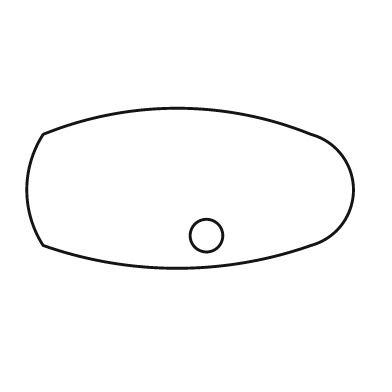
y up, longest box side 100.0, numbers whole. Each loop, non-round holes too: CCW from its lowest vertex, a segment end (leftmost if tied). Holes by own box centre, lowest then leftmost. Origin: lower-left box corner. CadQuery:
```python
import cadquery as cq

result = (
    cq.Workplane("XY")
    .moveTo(5.0, 7.0)
    .threePointArc((46.0, 0.0), (87.0, 7.0))
    .threePointArc((100.0, 24.0), (87.0, 41.0))
    .threePointArc((46.0, 49.0), (5.0, 41.0))
    .threePointArc((0.0, 24.0), (5.0, 7.0))
    .close()
    .moveTo(55.0, 10.0)
    .circle(5.0)
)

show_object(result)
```